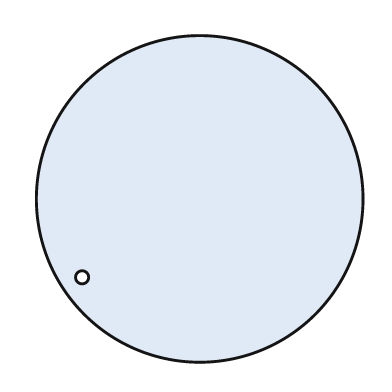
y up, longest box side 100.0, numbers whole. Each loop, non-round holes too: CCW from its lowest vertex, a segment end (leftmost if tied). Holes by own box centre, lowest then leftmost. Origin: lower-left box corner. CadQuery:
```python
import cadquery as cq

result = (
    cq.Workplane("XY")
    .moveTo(50.0, 50.0)
    .circle(50.0)
    .moveTo(14.0, 26.0)
    .circle(2.0)
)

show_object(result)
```